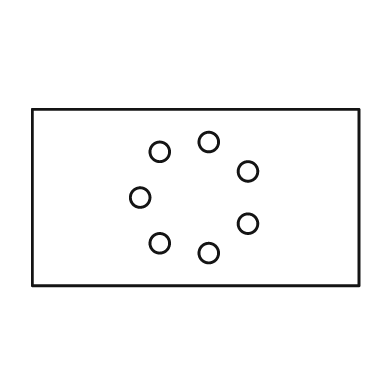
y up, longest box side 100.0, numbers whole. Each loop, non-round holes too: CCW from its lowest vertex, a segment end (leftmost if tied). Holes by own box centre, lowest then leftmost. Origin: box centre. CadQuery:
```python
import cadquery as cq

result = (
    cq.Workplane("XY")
    .moveTo(-50.0, -27.0)
    .lineTo(50.0, -27.0)
    .lineTo(50.0, 27.0)
    .lineTo(-50.0, 27.0)
    .close()
    .moveTo(4.0, -17.0)
    .circle(3.0)
    .moveTo(-11.0, -14.0)
    .circle(3.0)
    .moveTo(16.0, -8.0)
    .circle(3.0)
    .moveTo(-17.0, 0.0)
    .circle(3.0)
    .moveTo(16.0, 8.0)
    .circle(3.0)
    .moveTo(-11.0, 14.0)
    .circle(3.0)
    .moveTo(4.0, 17.0)
    .circle(3.0)
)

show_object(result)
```